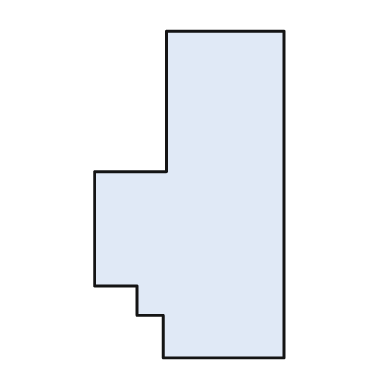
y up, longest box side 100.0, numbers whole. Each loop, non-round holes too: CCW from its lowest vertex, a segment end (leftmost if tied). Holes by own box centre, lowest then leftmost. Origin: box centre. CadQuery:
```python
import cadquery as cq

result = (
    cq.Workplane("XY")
    .moveTo(-8.0, -50.0)
    .lineTo(29.0, -50.0)
    .lineTo(29.0, 50.0)
    .lineTo(-7.0, 50.0)
    .lineTo(-7.0, 7.0)
    .lineTo(-29.0, 7.0)
    .lineTo(-29.0, -28.0)
    .lineTo(-16.0, -28.0)
    .lineTo(-16.0, -37.0)
    .lineTo(-8.0, -37.0)
    .close()
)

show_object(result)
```